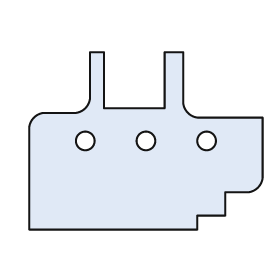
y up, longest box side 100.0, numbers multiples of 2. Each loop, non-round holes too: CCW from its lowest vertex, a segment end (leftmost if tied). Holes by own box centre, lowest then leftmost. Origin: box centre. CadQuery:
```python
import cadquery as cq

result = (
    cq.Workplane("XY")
    .moveTo(-50.0, -38.0)
    .lineTo(22.0, -38.0)
    .lineTo(22.0, -32.0)
    .lineTo(34.0, -32.0)
    .lineTo(34.0, -22.0)
    .lineTo(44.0, -22.0)
    .threePointArc((48.0, -20.0), (50.0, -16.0))
    .lineTo(50.0, 10.0)
    .lineTo(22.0, 10.0)
    .threePointArc((18.0, 12.0), (16.0, 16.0))
    .lineTo(16.0, 38.0)
    .lineTo(8.0, 38.0)
    .lineTo(8.0, 14.0)
    .lineTo(-18.0, 14.0)
    .lineTo(-18.0, 38.0)
    .lineTo(-24.0, 38.0)
    .lineTo(-24.0, 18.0)
    .threePointArc((-26.0, 14.0), (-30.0, 12.0))
    .lineTo(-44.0, 12.0)
    .threePointArc((-48.0, 10.0), (-50.0, 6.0))
    .close()
    .moveTo(-26.0, 0.0)
    .circle(4.0)
    .moveTo(0.0, 0.0)
    .circle(4.0)
    .moveTo(26.0, 0.0)
    .circle(4.0)
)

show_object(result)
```